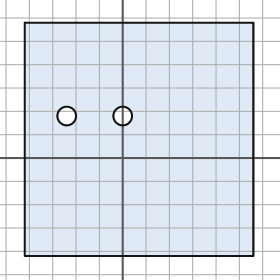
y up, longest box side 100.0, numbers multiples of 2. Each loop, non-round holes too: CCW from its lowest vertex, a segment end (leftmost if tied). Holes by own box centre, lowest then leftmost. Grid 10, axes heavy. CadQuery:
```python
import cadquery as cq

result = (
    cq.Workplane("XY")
    .moveTo(-42.0, -42.0)
    .lineTo(56.0, -42.0)
    .lineTo(56.0, 58.0)
    .lineTo(-42.0, 58.0)
    .close()
    .moveTo(-24.0, 18.0)
    .circle(4.0)
    .moveTo(0.0, 18.0)
    .circle(4.0)
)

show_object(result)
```